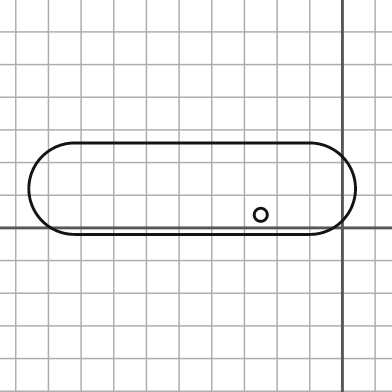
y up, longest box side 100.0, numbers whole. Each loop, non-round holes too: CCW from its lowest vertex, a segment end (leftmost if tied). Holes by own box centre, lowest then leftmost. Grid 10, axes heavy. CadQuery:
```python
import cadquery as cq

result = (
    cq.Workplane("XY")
    .moveTo(-82.0, -2.0)
    .lineTo(-10.0, -2.0)
    .threePointArc((4.0, 12.0), (-10.0, 26.0))
    .lineTo(-82.0, 26.0)
    .threePointArc((-96.0, 12.0), (-82.0, -2.0))
    .close()
    .moveTo(-25.0, 4.0)
    .circle(2.0)
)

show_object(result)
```